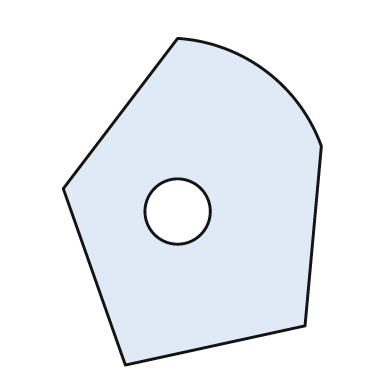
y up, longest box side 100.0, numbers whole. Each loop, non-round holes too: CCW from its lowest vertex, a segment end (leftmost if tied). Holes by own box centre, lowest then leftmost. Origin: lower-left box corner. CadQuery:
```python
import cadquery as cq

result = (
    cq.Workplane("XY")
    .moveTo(19.0, 0.0)
    .lineTo(74.0, 12.0)
    .lineTo(79.0, 67.0)
    .threePointArc((62.0, 90.0), (35.0, 100.0))
    .lineTo(0.0, 54.0)
    .close()
    .moveTo(35.0, 47.0)
    .circle(10.0)
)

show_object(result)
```